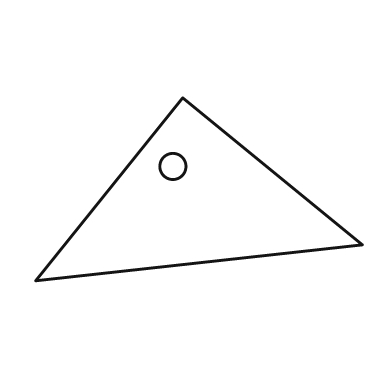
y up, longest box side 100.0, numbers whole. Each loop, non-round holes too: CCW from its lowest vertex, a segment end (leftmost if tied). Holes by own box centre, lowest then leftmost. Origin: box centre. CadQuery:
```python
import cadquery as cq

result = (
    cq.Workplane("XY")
    .moveTo(-50.0, -28.0)
    .lineTo(50.0, -17.0)
    .lineTo(-5.0, 28.0)
    .close()
    .moveTo(-8.0, 7.0)
    .circle(4.0)
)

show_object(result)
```